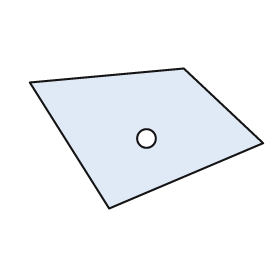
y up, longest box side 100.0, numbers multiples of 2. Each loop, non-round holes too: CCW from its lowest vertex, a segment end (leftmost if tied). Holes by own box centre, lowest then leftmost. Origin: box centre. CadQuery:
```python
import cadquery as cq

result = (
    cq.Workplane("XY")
    .moveTo(-16.0, -30.0)
    .lineTo(50.0, -2.0)
    .lineTo(16.0, 30.0)
    .lineTo(-50.0, 24.0)
    .close()
    .moveTo(0.0, 0.0)
    .circle(4.0)
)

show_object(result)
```